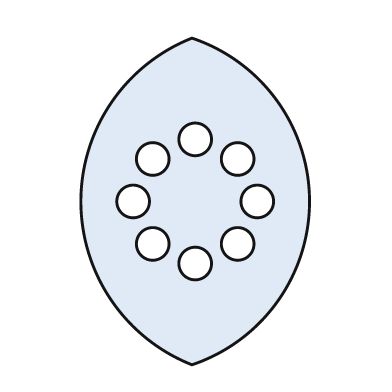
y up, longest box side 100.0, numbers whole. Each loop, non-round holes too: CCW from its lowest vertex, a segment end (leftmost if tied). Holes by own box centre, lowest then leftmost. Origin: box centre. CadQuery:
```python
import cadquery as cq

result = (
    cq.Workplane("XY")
    .moveTo(-1.0, -50.0)
    .threePointArc((35.0, 0.0), (-1.0, 50.0))
    .threePointArc((-35.0, 0.0), (-1.0, -50.0))
    .close()
    .moveTo(0.0, -19.0)
    .circle(5.0)
    .moveTo(-13.0, -13.0)
    .circle(5.0)
    .moveTo(13.0, -13.0)
    .circle(5.0)
    .moveTo(-19.0, 0.0)
    .circle(5.0)
    .moveTo(19.0, 0.0)
    .circle(5.0)
    .moveTo(-13.0, 13.0)
    .circle(5.0)
    .moveTo(13.0, 13.0)
    .circle(5.0)
    .moveTo(0.0, 19.0)
    .circle(5.0)
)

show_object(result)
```